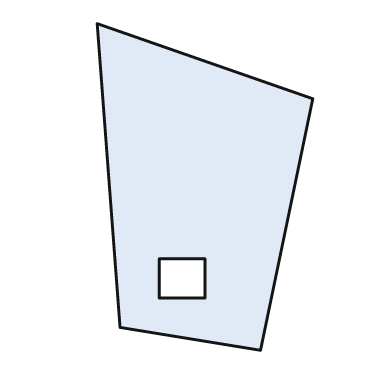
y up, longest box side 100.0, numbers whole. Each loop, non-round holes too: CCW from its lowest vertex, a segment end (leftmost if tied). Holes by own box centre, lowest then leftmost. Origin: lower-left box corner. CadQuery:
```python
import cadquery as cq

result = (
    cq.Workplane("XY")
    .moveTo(50.0, 0.0)
    .lineTo(66.0, 77.0)
    .lineTo(0.0, 100.0)
    .lineTo(7.0, 7.0)
    .close()
    .moveTo(19.0, 16.0)
    .lineTo(33.0, 16.0)
    .lineTo(33.0, 28.0)
    .lineTo(19.0, 28.0)
    .close()
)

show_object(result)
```